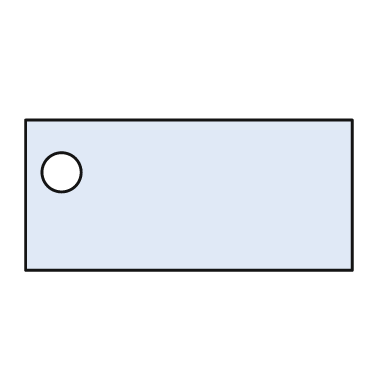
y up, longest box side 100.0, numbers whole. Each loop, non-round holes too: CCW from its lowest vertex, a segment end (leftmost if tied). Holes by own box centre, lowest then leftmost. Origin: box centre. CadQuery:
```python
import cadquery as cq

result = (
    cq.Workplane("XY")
    .moveTo(-50.0, -23.0)
    .lineTo(50.0, -23.0)
    .lineTo(50.0, 23.0)
    .lineTo(-50.0, 23.0)
    .close()
    .moveTo(-39.0, 7.0)
    .circle(6.0)
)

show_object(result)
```